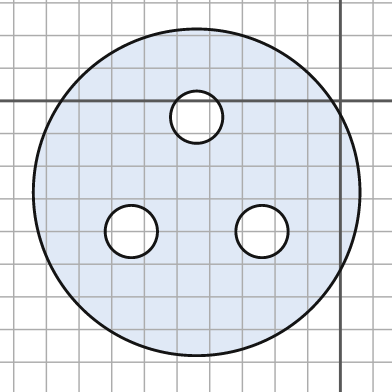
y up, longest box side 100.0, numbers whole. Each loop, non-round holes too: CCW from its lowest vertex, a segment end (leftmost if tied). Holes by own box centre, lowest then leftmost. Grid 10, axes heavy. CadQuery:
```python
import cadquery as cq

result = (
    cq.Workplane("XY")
    .moveTo(-44.0, -28.0)
    .circle(50.0)
    .moveTo(-64.0, -40.0)
    .circle(8.0)
    .moveTo(-24.0, -40.0)
    .circle(8.0)
    .moveTo(-44.0, -5.0)
    .circle(8.0)
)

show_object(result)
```